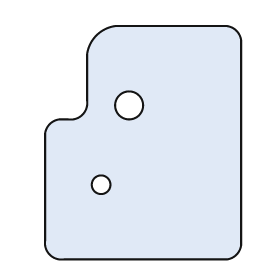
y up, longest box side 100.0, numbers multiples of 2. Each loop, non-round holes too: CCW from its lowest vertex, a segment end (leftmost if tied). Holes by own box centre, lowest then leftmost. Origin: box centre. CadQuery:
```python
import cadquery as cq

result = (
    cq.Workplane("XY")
    .moveTo(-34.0, -50.0)
    .lineTo(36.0, -50.0)
    .threePointArc((40.0, -48.0), (42.0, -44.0))
    .lineTo(42.0, 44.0)
    .threePointArc((40.0, 48.0), (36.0, 50.0))
    .lineTo(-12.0, 50.0)
    .threePointArc((-20.0, 46.0), (-24.0, 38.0))
    .lineTo(-24.0, 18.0)
    .threePointArc((-26.0, 12.0), (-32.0, 10.0))
    .lineTo(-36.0, 10.0)
    .threePointArc((-40.0, 8.0), (-42.0, 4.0))
    .lineTo(-42.0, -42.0)
    .threePointArc((-40.0, -48.0), (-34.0, -50.0))
    .close()
    .moveTo(-18.0, -18.0)
    .circle(4.0)
    .moveTo(-6.0, 16.0)
    .circle(6.0)
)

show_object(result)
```